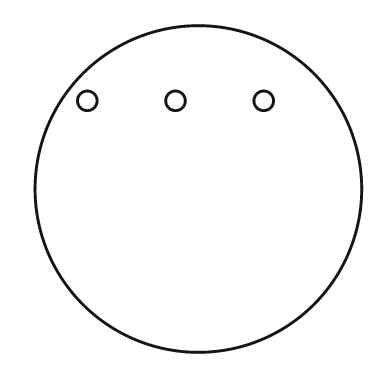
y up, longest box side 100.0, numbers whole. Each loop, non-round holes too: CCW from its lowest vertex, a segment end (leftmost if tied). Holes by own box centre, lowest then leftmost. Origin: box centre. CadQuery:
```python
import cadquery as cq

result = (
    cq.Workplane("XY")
    .moveTo(0.0, 0.0)
    .circle(50.0)
    .moveTo(-34.0, 27.0)
    .circle(3.0)
    .moveTo(-7.0, 27.0)
    .circle(3.0)
    .moveTo(20.0, 27.0)
    .circle(3.0)
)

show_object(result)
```